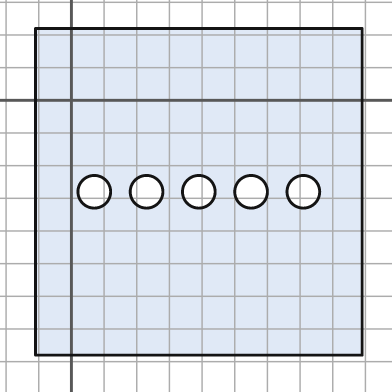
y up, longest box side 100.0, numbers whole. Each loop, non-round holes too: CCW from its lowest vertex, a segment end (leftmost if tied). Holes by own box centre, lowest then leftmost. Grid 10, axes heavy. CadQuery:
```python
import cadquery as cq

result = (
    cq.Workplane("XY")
    .moveTo(-11.0, -78.0)
    .lineTo(89.0, -78.0)
    .lineTo(89.0, 22.0)
    .lineTo(-11.0, 22.0)
    .close()
    .moveTo(7.0, -28.0)
    .circle(5.0)
    .moveTo(23.0, -28.0)
    .circle(5.0)
    .moveTo(39.0, -28.0)
    .circle(5.0)
    .moveTo(55.0, -28.0)
    .circle(5.0)
    .moveTo(71.0, -28.0)
    .circle(5.0)
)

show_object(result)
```